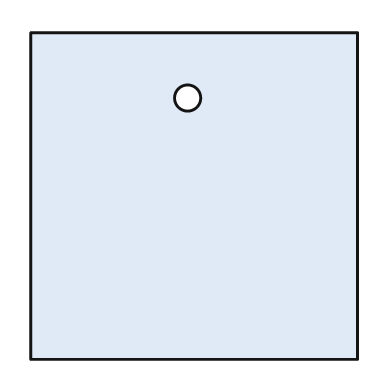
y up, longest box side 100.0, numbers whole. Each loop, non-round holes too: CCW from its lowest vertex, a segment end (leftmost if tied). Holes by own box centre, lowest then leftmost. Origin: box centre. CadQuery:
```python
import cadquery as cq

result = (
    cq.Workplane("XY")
    .moveTo(-50.0, -50.0)
    .lineTo(50.0, -50.0)
    .lineTo(50.0, 50.0)
    .lineTo(-50.0, 50.0)
    .close()
    .moveTo(-2.0, 30.0)
    .circle(4.0)
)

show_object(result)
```